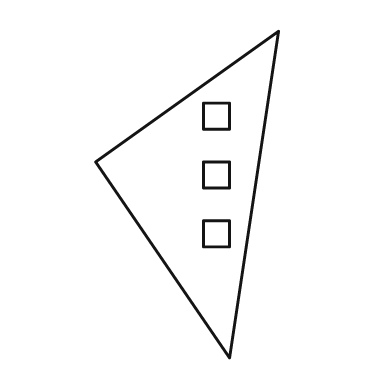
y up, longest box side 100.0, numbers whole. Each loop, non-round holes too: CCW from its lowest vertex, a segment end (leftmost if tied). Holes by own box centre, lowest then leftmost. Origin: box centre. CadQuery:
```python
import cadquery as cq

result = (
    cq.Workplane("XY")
    .moveTo(13.0, -50.0)
    .lineTo(28.0, 50.0)
    .lineTo(-28.0, 10.0)
    .close()
    .moveTo(5.0, -16.0)
    .lineTo(13.0, -16.0)
    .lineTo(13.0, -8.0)
    .lineTo(5.0, -8.0)
    .close()
    .moveTo(5.0, 2.0)
    .lineTo(13.0, 2.0)
    .lineTo(13.0, 10.0)
    .lineTo(5.0, 10.0)
    .close()
    .moveTo(5.0, 20.0)
    .lineTo(13.0, 20.0)
    .lineTo(13.0, 28.0)
    .lineTo(5.0, 28.0)
    .close()
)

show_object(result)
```